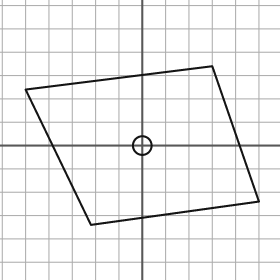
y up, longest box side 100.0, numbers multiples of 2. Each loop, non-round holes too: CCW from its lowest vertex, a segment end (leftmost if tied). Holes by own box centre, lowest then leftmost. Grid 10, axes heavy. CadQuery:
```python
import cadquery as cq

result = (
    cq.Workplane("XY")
    .moveTo(-22.0, -34.0)
    .lineTo(50.0, -24.0)
    .lineTo(30.0, 34.0)
    .lineTo(-50.0, 24.0)
    .close()
    .moveTo(0.0, 0.0)
    .circle(4.0)
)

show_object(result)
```